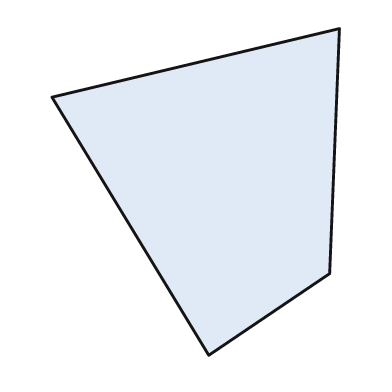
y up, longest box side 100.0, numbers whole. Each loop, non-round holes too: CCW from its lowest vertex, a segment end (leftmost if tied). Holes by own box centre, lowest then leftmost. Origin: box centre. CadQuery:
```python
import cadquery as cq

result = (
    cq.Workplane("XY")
    .moveTo(4.0, -50.0)
    .lineTo(41.0, -25.0)
    .lineTo(44.0, 50.0)
    .lineTo(-44.0, 29.0)
    .close()
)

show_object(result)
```